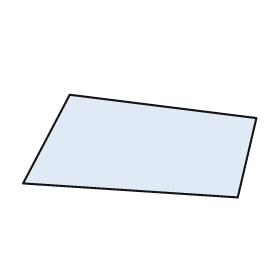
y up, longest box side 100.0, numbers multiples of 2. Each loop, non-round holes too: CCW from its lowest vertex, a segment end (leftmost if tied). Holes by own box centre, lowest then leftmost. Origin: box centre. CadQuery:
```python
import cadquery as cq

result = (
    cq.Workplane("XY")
    .moveTo(42.0, -22.0)
    .lineTo(50.0, 12.0)
    .lineTo(-30.0, 22.0)
    .lineTo(-50.0, -16.0)
    .close()
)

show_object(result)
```